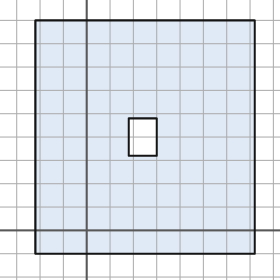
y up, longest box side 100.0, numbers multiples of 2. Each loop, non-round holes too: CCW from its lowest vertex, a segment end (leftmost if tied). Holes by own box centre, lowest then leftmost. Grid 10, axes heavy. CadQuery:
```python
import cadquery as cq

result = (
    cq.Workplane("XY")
    .moveTo(-22.0, -10.0)
    .lineTo(72.0, -10.0)
    .lineTo(72.0, 90.0)
    .lineTo(-22.0, 90.0)
    .close()
    .moveTo(18.0, 32.0)
    .lineTo(30.0, 32.0)
    .lineTo(30.0, 48.0)
    .lineTo(18.0, 48.0)
    .close()
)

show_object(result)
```